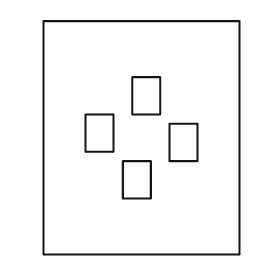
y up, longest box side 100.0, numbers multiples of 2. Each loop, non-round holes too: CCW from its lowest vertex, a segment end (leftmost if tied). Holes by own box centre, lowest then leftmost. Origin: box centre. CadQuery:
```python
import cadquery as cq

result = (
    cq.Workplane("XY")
    .moveTo(-42.0, -50.0)
    .lineTo(42.0, -50.0)
    .lineTo(42.0, 50.0)
    .lineTo(-42.0, 50.0)
    .close()
    .moveTo(-8.0, -26.0)
    .lineTo(4.0, -26.0)
    .lineTo(4.0, -10.0)
    .lineTo(-8.0, -10.0)
    .close()
    .moveTo(12.0, -10.0)
    .lineTo(24.0, -10.0)
    .lineTo(24.0, 6.0)
    .lineTo(12.0, 6.0)
    .close()
    .moveTo(-24.0, -6.0)
    .lineTo(-12.0, -6.0)
    .lineTo(-12.0, 10.0)
    .lineTo(-24.0, 10.0)
    .close()
    .moveTo(-4.0, 10.0)
    .lineTo(8.0, 10.0)
    .lineTo(8.0, 26.0)
    .lineTo(-4.0, 26.0)
    .close()
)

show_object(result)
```